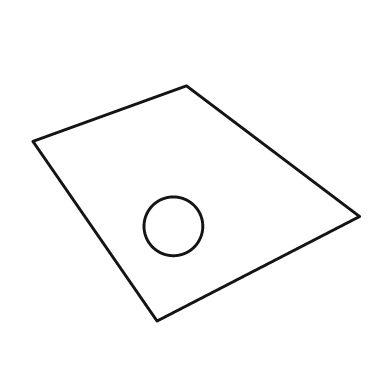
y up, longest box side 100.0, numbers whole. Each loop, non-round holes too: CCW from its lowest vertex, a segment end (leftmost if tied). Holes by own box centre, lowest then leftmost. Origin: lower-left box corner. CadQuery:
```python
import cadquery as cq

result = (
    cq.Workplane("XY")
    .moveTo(38.0, 0.0)
    .lineTo(100.0, 32.0)
    .lineTo(47.0, 72.0)
    .lineTo(0.0, 55.0)
    .close()
    .moveTo(43.0, 29.0)
    .circle(9.0)
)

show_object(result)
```